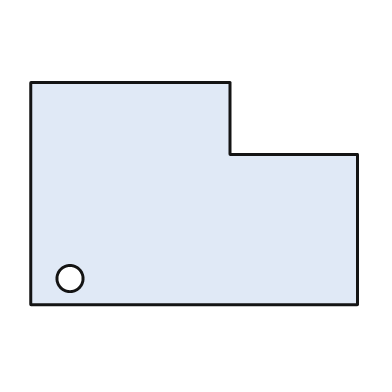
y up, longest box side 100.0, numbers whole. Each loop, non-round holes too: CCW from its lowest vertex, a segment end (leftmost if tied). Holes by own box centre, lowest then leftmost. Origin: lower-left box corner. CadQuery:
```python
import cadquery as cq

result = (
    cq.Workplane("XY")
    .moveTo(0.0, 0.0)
    .lineTo(100.0, 0.0)
    .lineTo(100.0, 46.0)
    .lineTo(61.0, 46.0)
    .lineTo(61.0, 68.0)
    .lineTo(0.0, 68.0)
    .close()
    .moveTo(12.0, 8.0)
    .circle(4.0)
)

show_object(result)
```